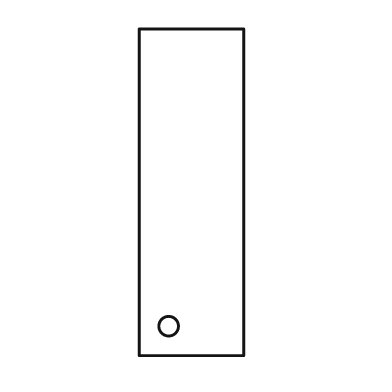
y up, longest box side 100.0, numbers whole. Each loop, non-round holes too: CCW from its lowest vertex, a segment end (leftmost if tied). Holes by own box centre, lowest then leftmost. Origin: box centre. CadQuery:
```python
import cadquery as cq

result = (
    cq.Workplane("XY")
    .moveTo(-16.0, -50.0)
    .lineTo(16.0, -50.0)
    .lineTo(16.0, 50.0)
    .lineTo(-16.0, 50.0)
    .close()
    .moveTo(-7.0, -41.0)
    .circle(3.0)
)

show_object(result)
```